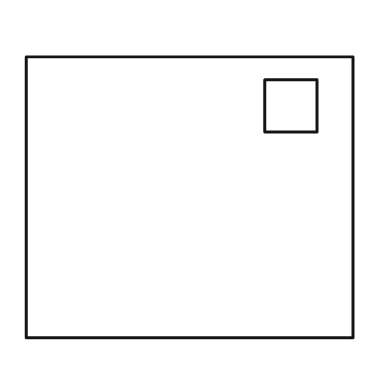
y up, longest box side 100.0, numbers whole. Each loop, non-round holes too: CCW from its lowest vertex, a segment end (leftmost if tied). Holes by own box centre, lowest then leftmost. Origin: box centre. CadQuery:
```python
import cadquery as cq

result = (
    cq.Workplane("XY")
    .moveTo(-50.0, -43.0)
    .lineTo(50.0, -43.0)
    .lineTo(50.0, 43.0)
    .lineTo(-50.0, 43.0)
    .close()
    .moveTo(23.0, 20.0)
    .lineTo(39.0, 20.0)
    .lineTo(39.0, 36.0)
    .lineTo(23.0, 36.0)
    .close()
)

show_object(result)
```